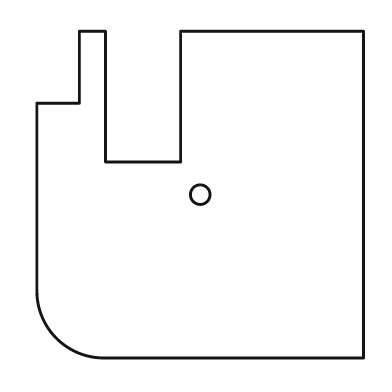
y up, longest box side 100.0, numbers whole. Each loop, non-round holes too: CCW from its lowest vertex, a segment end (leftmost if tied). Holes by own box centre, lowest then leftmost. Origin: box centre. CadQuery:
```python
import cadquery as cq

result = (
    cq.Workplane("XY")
    .moveTo(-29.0, -50.0)
    .lineTo(50.0, -50.0)
    .lineTo(50.0, 50.0)
    .lineTo(-6.0, 50.0)
    .lineTo(-6.0, 10.0)
    .lineTo(-29.0, 10.0)
    .lineTo(-29.0, 50.0)
    .lineTo(-37.0, 50.0)
    .lineTo(-37.0, 28.0)
    .lineTo(-50.0, 28.0)
    .lineTo(-50.0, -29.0)
    .threePointArc((-44.0, -44.0), (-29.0, -50.0))
    .close()
    .moveTo(0.0, 0.0)
    .circle(3.0)
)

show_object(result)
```